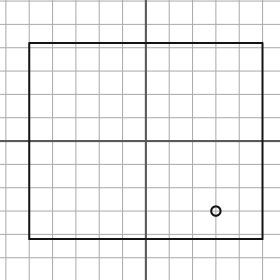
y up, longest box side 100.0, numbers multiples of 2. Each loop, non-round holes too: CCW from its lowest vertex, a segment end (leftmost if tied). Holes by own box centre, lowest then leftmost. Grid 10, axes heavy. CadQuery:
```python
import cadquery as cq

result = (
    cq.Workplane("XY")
    .moveTo(-50.0, -42.0)
    .lineTo(50.0, -42.0)
    .lineTo(50.0, 42.0)
    .lineTo(-50.0, 42.0)
    .close()
    .moveTo(30.0, -30.0)
    .circle(2.0)
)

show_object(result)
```